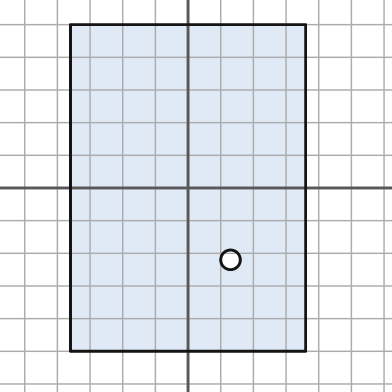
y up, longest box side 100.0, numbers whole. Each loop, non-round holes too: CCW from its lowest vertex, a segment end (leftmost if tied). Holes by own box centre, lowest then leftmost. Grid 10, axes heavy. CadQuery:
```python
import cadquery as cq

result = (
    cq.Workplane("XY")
    .moveTo(-36.0, -50.0)
    .lineTo(36.0, -50.0)
    .lineTo(36.0, 50.0)
    .lineTo(-36.0, 50.0)
    .close()
    .moveTo(13.0, -22.0)
    .circle(3.0)
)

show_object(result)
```